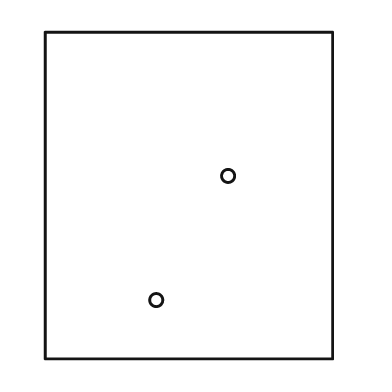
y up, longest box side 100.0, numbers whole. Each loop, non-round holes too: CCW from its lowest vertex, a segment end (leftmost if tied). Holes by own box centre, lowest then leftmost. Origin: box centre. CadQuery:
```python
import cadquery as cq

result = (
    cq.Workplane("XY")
    .moveTo(-44.0, -50.0)
    .lineTo(44.0, -50.0)
    .lineTo(44.0, 50.0)
    .lineTo(-44.0, 50.0)
    .close()
    .moveTo(-10.0, -32.0)
    .circle(2.0)
    .moveTo(12.0, 6.0)
    .circle(2.0)
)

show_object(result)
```